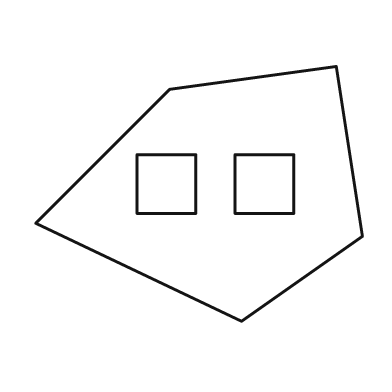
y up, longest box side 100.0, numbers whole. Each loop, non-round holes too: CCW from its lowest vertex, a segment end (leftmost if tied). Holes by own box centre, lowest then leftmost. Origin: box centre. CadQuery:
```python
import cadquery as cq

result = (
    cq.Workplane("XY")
    .moveTo(13.0, -39.0)
    .lineTo(50.0, -13.0)
    .lineTo(42.0, 39.0)
    .lineTo(-9.0, 32.0)
    .lineTo(-50.0, -9.0)
    .close()
    .moveTo(-19.0, -6.0)
    .lineTo(-1.0, -6.0)
    .lineTo(-1.0, 12.0)
    .lineTo(-19.0, 12.0)
    .close()
    .moveTo(11.0, -6.0)
    .lineTo(29.0, -6.0)
    .lineTo(29.0, 12.0)
    .lineTo(11.0, 12.0)
    .close()
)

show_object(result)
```